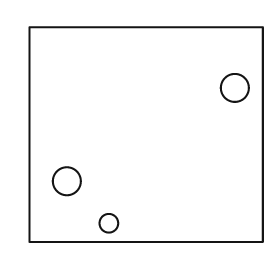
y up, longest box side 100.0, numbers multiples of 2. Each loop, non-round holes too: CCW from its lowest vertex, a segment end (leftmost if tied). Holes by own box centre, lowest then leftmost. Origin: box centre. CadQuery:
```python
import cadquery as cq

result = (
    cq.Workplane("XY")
    .moveTo(-50.0, -46.0)
    .lineTo(50.0, -46.0)
    .lineTo(50.0, 46.0)
    .lineTo(-50.0, 46.0)
    .close()
    .moveTo(-16.0, -38.0)
    .circle(4.0)
    .moveTo(-34.0, -20.0)
    .circle(6.0)
    .moveTo(38.0, 20.0)
    .circle(6.0)
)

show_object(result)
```